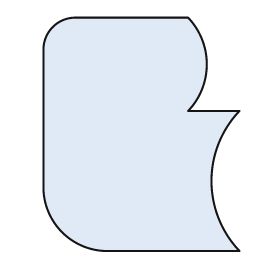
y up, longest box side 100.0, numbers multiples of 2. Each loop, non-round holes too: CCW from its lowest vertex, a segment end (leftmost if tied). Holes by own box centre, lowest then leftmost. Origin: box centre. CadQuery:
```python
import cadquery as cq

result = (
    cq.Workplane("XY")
    .moveTo(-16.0, -50.0)
    .lineTo(42.0, -50.0)
    .threePointArc((30.0, -20.0), (42.0, 10.0))
    .lineTo(20.0, 10.0)
    .threePointArc((28.0, 30.0), (20.0, 50.0))
    .lineTo(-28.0, 50.0)
    .threePointArc((-38.0, 46.0), (-42.0, 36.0))
    .lineTo(-42.0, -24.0)
    .threePointArc((-34.0, -42.0), (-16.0, -50.0))
    .close()
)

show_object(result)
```